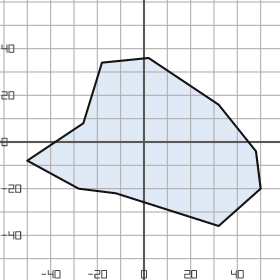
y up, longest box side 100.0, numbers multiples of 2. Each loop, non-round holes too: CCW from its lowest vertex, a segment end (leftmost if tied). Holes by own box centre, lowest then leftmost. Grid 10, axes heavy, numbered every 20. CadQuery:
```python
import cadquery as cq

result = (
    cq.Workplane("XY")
    .moveTo(32.0, -36.0)
    .lineTo(50.0, -20.0)
    .lineTo(48.0, -4.0)
    .lineTo(32.0, 16.0)
    .lineTo(2.0, 36.0)
    .lineTo(-18.0, 34.0)
    .lineTo(-26.0, 8.0)
    .lineTo(-50.0, -8.0)
    .lineTo(-28.0, -20.0)
    .lineTo(-12.0, -22.0)
    .close()
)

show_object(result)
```